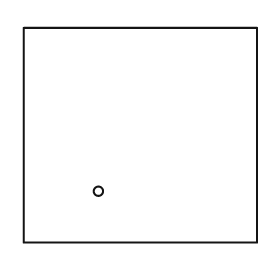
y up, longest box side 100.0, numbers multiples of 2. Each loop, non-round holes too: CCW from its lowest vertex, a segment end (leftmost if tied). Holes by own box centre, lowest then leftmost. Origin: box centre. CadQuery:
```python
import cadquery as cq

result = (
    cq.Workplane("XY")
    .moveTo(-50.0, -46.0)
    .lineTo(50.0, -46.0)
    .lineTo(50.0, 46.0)
    .lineTo(-50.0, 46.0)
    .close()
    .moveTo(-18.0, -24.0)
    .circle(2.0)
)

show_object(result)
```